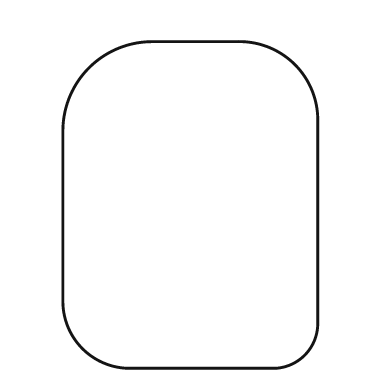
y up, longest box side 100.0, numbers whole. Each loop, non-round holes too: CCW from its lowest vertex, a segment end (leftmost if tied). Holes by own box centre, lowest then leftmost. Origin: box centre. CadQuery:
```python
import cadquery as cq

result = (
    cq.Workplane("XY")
    .moveTo(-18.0, -50.0)
    .lineTo(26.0, -50.0)
    .threePointArc((35.0, -46.0), (39.0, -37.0))
    .lineTo(39.0, 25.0)
    .threePointArc((32.0, 43.0), (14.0, 50.0))
    .lineTo(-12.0, 50.0)
    .threePointArc((-31.0, 42.0), (-39.0, 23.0))
    .lineTo(-39.0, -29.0)
    .threePointArc((-33.0, -44.0), (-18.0, -50.0))
    .close()
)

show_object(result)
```